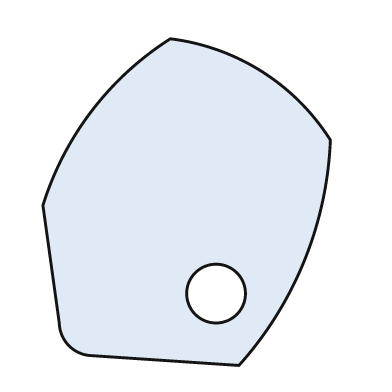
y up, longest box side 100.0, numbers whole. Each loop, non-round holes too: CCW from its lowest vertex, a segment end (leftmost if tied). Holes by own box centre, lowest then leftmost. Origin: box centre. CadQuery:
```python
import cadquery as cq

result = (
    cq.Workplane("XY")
    .moveTo(16.0, -50.0)
    .threePointArc((36.0, -18.0), (44.0, 19.0))
    .threePointArc((23.0, 40.0), (-5.0, 50.0))
    .threePointArc((-29.0, 28.0), (-44.0, -1.0))
    .lineTo(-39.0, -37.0)
    .threePointArc((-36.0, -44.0), (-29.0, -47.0))
    .close()
    .moveTo(9.0, -28.0)
    .circle(9.0)
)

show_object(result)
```